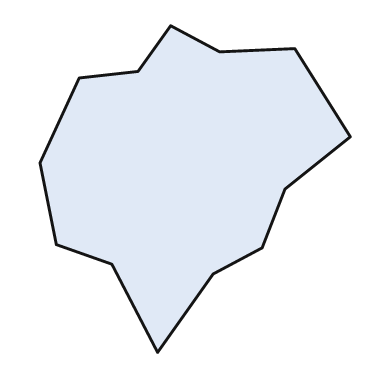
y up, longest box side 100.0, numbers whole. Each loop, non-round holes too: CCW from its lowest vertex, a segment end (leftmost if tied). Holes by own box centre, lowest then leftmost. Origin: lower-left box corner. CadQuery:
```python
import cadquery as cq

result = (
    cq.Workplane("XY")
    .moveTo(36.0, 0.0)
    .lineTo(53.0, 24.0)
    .lineTo(68.0, 32.0)
    .lineTo(75.0, 50.0)
    .lineTo(95.0, 66.0)
    .lineTo(78.0, 93.0)
    .lineTo(55.0, 92.0)
    .lineTo(40.0, 100.0)
    .lineTo(30.0, 86.0)
    .lineTo(12.0, 84.0)
    .lineTo(0.0, 58.0)
    .lineTo(5.0, 33.0)
    .lineTo(22.0, 27.0)
    .close()
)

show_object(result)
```